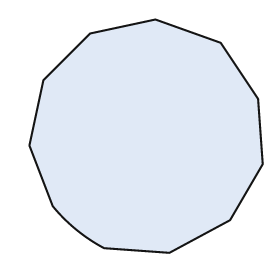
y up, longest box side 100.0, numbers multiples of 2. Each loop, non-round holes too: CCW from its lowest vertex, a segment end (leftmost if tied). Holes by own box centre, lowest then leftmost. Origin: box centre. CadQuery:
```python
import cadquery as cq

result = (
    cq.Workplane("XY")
    .moveTo(10.0, -50.0)
    .lineTo(36.0, -36.0)
    .lineTo(50.0, -12.0)
    .lineTo(48.0, 16.0)
    .lineTo(32.0, 40.0)
    .lineTo(4.0, 50.0)
    .lineTo(-24.0, 44.0)
    .lineTo(-44.0, 24.0)
    .lineTo(-50.0, -4.0)
    .lineTo(-40.0, -30.0)
    .threePointArc((-30.0, -40.0), (-18.0, -48.0))
    .close()
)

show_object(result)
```